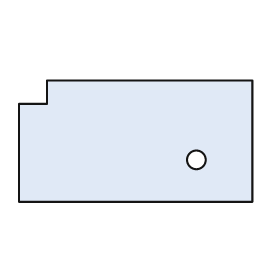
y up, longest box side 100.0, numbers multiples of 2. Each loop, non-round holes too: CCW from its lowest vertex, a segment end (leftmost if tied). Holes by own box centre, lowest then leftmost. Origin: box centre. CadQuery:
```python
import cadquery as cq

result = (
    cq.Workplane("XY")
    .moveTo(-50.0, -26.0)
    .lineTo(50.0, -26.0)
    .lineTo(50.0, 26.0)
    .lineTo(-38.0, 26.0)
    .lineTo(-38.0, 16.0)
    .lineTo(-50.0, 16.0)
    .close()
    .moveTo(26.0, -8.0)
    .circle(4.0)
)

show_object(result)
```